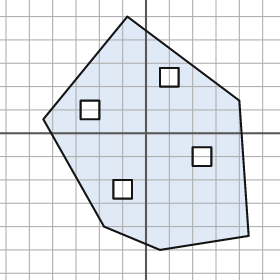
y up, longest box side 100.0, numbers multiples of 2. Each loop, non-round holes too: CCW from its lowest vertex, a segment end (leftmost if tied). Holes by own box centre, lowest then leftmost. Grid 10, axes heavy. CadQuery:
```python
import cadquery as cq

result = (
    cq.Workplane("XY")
    .moveTo(6.0, -50.0)
    .lineTo(44.0, -44.0)
    .lineTo(40.0, 14.0)
    .lineTo(-8.0, 50.0)
    .lineTo(-44.0, 6.0)
    .lineTo(-18.0, -40.0)
    .close()
    .moveTo(-14.0, -28.0)
    .lineTo(-6.0, -28.0)
    .lineTo(-6.0, -20.0)
    .lineTo(-14.0, -20.0)
    .close()
    .moveTo(20.0, -14.0)
    .lineTo(28.0, -14.0)
    .lineTo(28.0, -6.0)
    .lineTo(20.0, -6.0)
    .close()
    .moveTo(-28.0, 6.0)
    .lineTo(-20.0, 6.0)
    .lineTo(-20.0, 14.0)
    .lineTo(-28.0, 14.0)
    .close()
    .moveTo(6.0, 20.0)
    .lineTo(14.0, 20.0)
    .lineTo(14.0, 28.0)
    .lineTo(6.0, 28.0)
    .close()
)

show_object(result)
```